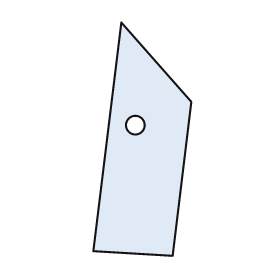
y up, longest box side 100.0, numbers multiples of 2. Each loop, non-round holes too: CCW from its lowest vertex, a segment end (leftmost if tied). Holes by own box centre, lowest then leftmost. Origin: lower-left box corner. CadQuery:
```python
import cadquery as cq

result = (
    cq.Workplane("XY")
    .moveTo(34.0, 0.0)
    .lineTo(42.0, 66.0)
    .lineTo(12.0, 100.0)
    .lineTo(0.0, 2.0)
    .close()
    .moveTo(18.0, 56.0)
    .circle(4.0)
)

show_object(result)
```